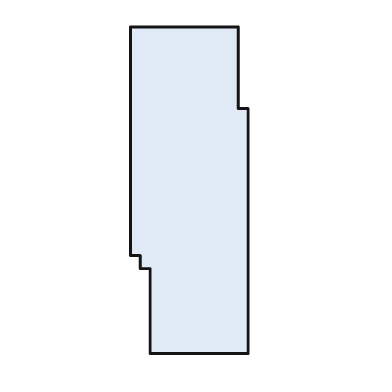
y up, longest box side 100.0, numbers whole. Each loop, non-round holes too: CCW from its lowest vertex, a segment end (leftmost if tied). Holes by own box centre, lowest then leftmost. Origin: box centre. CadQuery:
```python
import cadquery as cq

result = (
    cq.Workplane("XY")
    .moveTo(-12.0, -50.0)
    .lineTo(18.0, -50.0)
    .lineTo(18.0, 25.0)
    .lineTo(15.0, 25.0)
    .lineTo(15.0, 50.0)
    .lineTo(-18.0, 50.0)
    .lineTo(-18.0, -20.0)
    .lineTo(-15.0, -20.0)
    .lineTo(-15.0, -24.0)
    .lineTo(-12.0, -24.0)
    .close()
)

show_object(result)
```